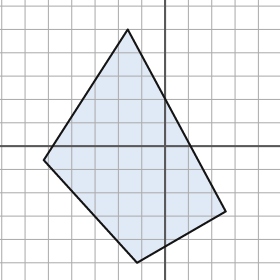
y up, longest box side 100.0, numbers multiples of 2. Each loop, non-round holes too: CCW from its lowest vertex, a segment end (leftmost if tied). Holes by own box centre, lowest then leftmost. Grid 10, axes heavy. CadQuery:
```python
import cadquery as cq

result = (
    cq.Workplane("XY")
    .moveTo(-12.0, -50.0)
    .lineTo(26.0, -28.0)
    .lineTo(-16.0, 50.0)
    .lineTo(-52.0, -6.0)
    .close()
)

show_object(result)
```